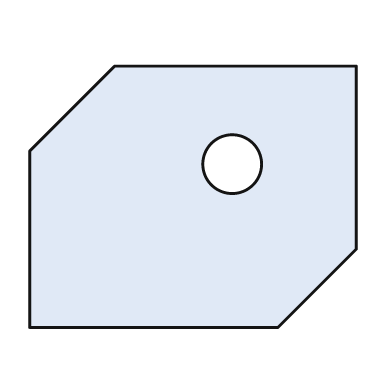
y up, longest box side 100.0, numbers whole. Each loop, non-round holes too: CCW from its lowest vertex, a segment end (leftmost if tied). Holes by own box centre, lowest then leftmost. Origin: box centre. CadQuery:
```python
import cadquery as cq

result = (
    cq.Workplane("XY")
    .moveTo(-50.0, -40.0)
    .lineTo(26.0, -40.0)
    .lineTo(50.0, -16.0)
    .lineTo(50.0, 40.0)
    .lineTo(-24.0, 40.0)
    .lineTo(-50.0, 14.0)
    .close()
    .moveTo(12.0, 10.0)
    .circle(9.0)
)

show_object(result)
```